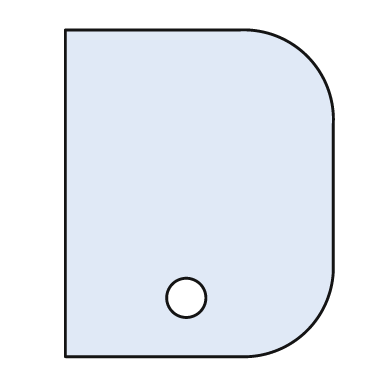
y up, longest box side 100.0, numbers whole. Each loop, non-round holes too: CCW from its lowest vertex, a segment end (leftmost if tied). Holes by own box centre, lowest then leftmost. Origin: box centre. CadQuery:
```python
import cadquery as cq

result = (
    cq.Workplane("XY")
    .moveTo(-41.0, -50.0)
    .lineTo(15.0, -50.0)
    .threePointArc((33.0, -42.0), (41.0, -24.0))
    .lineTo(41.0, 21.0)
    .threePointArc((33.0, 42.0), (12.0, 50.0))
    .lineTo(-41.0, 50.0)
    .close()
    .moveTo(-4.0, -32.0)
    .circle(6.0)
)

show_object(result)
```